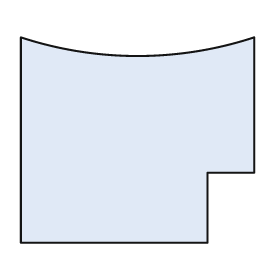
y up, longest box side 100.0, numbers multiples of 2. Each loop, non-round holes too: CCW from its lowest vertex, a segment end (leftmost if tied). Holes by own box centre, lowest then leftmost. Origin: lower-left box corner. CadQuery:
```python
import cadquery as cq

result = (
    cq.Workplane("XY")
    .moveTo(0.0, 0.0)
    .lineTo(80.0, 0.0)
    .lineTo(80.0, 30.0)
    .lineTo(100.0, 30.0)
    .lineTo(100.0, 88.0)
    .threePointArc((50.0, 80.0), (0.0, 88.0))
    .close()
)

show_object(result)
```